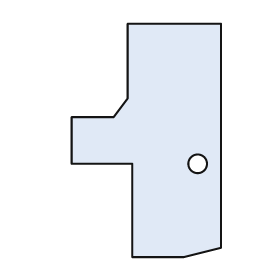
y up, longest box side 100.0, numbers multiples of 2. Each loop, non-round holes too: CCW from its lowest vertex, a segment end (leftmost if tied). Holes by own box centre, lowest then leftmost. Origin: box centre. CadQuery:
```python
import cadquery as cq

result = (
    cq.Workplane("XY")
    .moveTo(-6.0, -50.0)
    .lineTo(16.0, -50.0)
    .lineTo(32.0, -46.0)
    .lineTo(32.0, 50.0)
    .lineTo(-8.0, 50.0)
    .lineTo(-8.0, 18.0)
    .lineTo(-14.0, 10.0)
    .lineTo(-32.0, 10.0)
    .lineTo(-32.0, -10.0)
    .lineTo(-6.0, -10.0)
    .close()
    .moveTo(22.0, -10.0)
    .circle(4.0)
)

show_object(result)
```